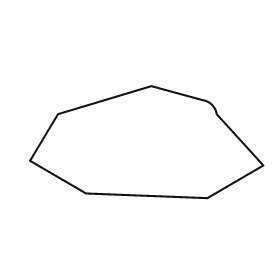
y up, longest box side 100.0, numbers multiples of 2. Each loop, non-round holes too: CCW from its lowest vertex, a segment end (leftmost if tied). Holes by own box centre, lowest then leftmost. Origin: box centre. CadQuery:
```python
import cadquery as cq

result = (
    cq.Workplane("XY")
    .moveTo(26.0, -24.0)
    .lineTo(50.0, -10.0)
    .lineTo(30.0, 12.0)
    .threePointArc((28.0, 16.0), (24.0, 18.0))
    .lineTo(2.0, 24.0)
    .lineTo(-38.0, 12.0)
    .lineTo(-50.0, -8.0)
    .lineTo(-26.0, -22.0)
    .close()
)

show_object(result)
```